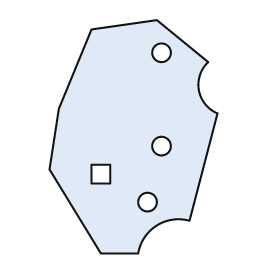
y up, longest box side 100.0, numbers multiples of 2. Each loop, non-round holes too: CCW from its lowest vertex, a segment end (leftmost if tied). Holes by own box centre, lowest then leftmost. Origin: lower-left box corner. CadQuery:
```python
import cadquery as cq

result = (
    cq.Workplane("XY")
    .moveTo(22.0, 0.0)
    .lineTo(38.0, 0.0)
    .threePointArc((46.0, 12.0), (60.0, 14.0))
    .lineTo(72.0, 60.0)
    .threePointArc((64.0, 70.0), (68.0, 82.0))
    .lineTo(46.0, 100.0)
    .lineTo(18.0, 96.0)
    .lineTo(4.0, 62.0)
    .lineTo(0.0, 36.0)
    .close()
    .moveTo(42.0, 22.0)
    .circle(4.0)
    .moveTo(18.0, 30.0)
    .lineTo(26.0, 30.0)
    .lineTo(26.0, 38.0)
    .lineTo(18.0, 38.0)
    .close()
    .moveTo(48.0, 46.0)
    .circle(4.0)
    .moveTo(48.0, 86.0)
    .circle(4.0)
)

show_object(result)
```